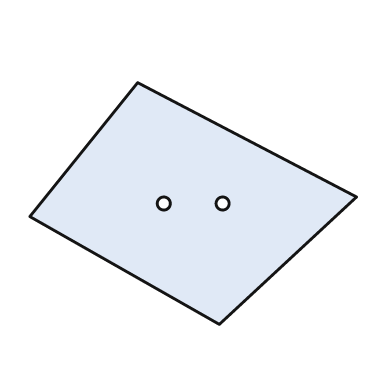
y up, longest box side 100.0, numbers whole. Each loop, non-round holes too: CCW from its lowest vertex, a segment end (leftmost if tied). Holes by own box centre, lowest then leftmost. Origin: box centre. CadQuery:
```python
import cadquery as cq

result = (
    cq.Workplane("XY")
    .moveTo(8.0, -37.0)
    .lineTo(50.0, 2.0)
    .lineTo(-17.0, 37.0)
    .lineTo(-50.0, -4.0)
    .close()
    .moveTo(-9.0, 0.0)
    .circle(2.0)
    .moveTo(9.0, 0.0)
    .circle(2.0)
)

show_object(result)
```